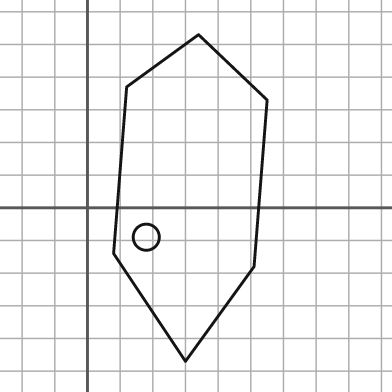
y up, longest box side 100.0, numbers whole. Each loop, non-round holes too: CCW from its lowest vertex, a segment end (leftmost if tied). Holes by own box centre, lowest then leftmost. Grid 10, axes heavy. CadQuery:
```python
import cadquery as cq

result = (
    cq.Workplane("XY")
    .moveTo(30.0, -47.0)
    .lineTo(51.0, -18.0)
    .lineTo(55.0, 33.0)
    .lineTo(34.0, 53.0)
    .lineTo(12.0, 37.0)
    .lineTo(8.0, -14.0)
    .close()
    .moveTo(18.0, -9.0)
    .circle(4.0)
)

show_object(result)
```